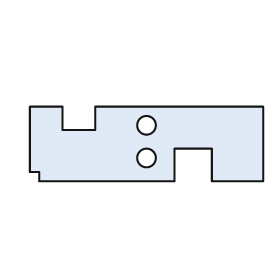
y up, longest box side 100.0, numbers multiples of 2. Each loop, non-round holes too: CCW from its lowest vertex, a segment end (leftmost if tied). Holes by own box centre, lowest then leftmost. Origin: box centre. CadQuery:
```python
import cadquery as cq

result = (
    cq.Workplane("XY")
    .moveTo(-46.0, -16.0)
    .lineTo(12.0, -16.0)
    .lineTo(12.0, -2.0)
    .lineTo(28.0, -2.0)
    .lineTo(28.0, -16.0)
    .lineTo(50.0, -16.0)
    .lineTo(50.0, 16.0)
    .lineTo(-22.0, 16.0)
    .lineTo(-22.0, 6.0)
    .lineTo(-36.0, 6.0)
    .lineTo(-36.0, 16.0)
    .lineTo(-50.0, 16.0)
    .lineTo(-50.0, -12.0)
    .lineTo(-46.0, -12.0)
    .close()
    .moveTo(0.0, -6.0)
    .circle(4.0)
    .moveTo(0.0, 8.0)
    .circle(4.0)
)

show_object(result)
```